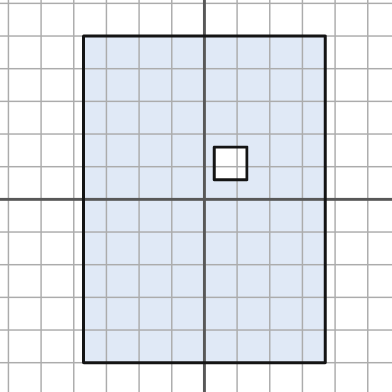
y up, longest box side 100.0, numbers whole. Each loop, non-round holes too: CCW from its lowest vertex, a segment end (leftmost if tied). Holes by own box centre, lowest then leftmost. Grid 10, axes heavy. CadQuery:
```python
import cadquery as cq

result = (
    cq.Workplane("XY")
    .moveTo(-37.0, -50.0)
    .lineTo(37.0, -50.0)
    .lineTo(37.0, 50.0)
    .lineTo(-37.0, 50.0)
    .close()
    .moveTo(3.0, 6.0)
    .lineTo(13.0, 6.0)
    .lineTo(13.0, 16.0)
    .lineTo(3.0, 16.0)
    .close()
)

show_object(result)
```